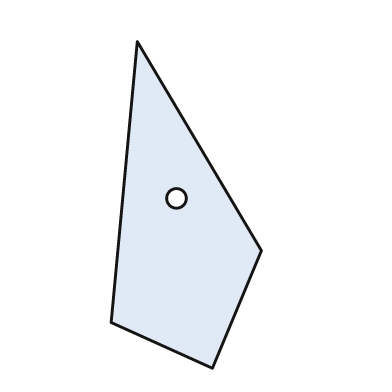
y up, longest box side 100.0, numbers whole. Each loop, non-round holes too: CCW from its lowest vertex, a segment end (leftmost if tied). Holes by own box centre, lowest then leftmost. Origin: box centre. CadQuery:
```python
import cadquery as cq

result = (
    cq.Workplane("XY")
    .moveTo(8.0, -50.0)
    .lineTo(23.0, -14.0)
    .lineTo(-15.0, 50.0)
    .lineTo(-23.0, -36.0)
    .close()
    .moveTo(-3.0, 2.0)
    .circle(3.0)
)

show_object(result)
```